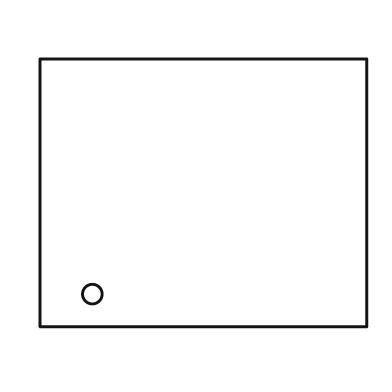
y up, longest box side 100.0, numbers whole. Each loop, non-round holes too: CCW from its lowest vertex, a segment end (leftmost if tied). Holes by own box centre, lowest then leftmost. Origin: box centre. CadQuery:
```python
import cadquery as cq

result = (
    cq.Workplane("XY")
    .moveTo(-50.0, -41.0)
    .lineTo(50.0, -41.0)
    .lineTo(50.0, 41.0)
    .lineTo(-50.0, 41.0)
    .close()
    .moveTo(-34.0, -31.0)
    .circle(3.0)
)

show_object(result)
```